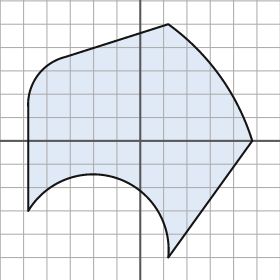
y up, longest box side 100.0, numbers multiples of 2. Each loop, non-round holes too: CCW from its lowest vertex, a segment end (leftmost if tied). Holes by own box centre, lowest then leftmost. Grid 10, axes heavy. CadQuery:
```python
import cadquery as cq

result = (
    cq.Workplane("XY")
    .moveTo(12.0, -50.0)
    .lineTo(48.0, 0.0)
    .threePointArc((34.0, 28.0), (12.0, 50.0))
    .lineTo(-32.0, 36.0)
    .threePointArc((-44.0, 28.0), (-48.0, 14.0))
    .lineTo(-48.0, -30.0)
    .threePointArc((-10.0, -16.0), (12.0, -50.0))
    .close()
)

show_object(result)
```